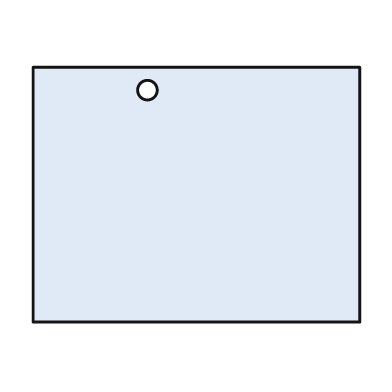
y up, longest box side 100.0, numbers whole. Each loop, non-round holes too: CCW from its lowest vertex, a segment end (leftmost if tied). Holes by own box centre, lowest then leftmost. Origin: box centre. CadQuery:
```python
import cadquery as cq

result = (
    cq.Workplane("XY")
    .moveTo(-50.0, -39.0)
    .lineTo(50.0, -39.0)
    .lineTo(50.0, 39.0)
    .lineTo(-50.0, 39.0)
    .close()
    .moveTo(-15.0, 32.0)
    .circle(3.0)
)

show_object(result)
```